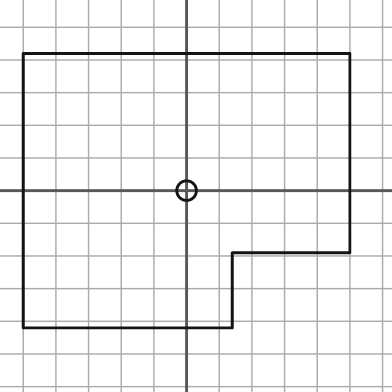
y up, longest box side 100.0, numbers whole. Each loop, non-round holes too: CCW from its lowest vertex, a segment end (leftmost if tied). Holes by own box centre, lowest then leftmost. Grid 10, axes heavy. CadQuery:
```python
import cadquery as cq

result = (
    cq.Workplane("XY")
    .moveTo(-50.0, -42.0)
    .lineTo(14.0, -42.0)
    .lineTo(14.0, -19.0)
    .lineTo(50.0, -19.0)
    .lineTo(50.0, 42.0)
    .lineTo(-50.0, 42.0)
    .close()
    .moveTo(0.0, 0.0)
    .circle(3.0)
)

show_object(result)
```